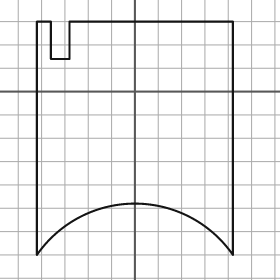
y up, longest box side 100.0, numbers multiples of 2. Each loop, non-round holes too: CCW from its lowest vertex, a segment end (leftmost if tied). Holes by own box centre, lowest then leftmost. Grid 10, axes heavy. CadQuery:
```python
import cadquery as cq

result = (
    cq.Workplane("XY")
    .moveTo(-42.0, -70.0)
    .threePointArc((0.0, -48.0), (42.0, -70.0))
    .lineTo(42.0, 30.0)
    .lineTo(-28.0, 30.0)
    .lineTo(-28.0, 14.0)
    .lineTo(-36.0, 14.0)
    .lineTo(-36.0, 30.0)
    .lineTo(-42.0, 30.0)
    .close()
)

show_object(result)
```